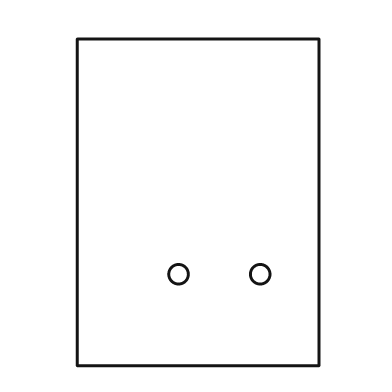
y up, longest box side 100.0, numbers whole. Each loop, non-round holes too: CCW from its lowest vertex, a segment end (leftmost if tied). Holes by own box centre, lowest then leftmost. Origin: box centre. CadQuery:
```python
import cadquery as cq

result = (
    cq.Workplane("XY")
    .moveTo(-37.0, -50.0)
    .lineTo(37.0, -50.0)
    .lineTo(37.0, 50.0)
    .lineTo(-37.0, 50.0)
    .close()
    .moveTo(-6.0, -22.0)
    .circle(3.0)
    .moveTo(19.0, -22.0)
    .circle(3.0)
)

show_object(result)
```